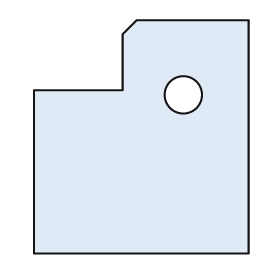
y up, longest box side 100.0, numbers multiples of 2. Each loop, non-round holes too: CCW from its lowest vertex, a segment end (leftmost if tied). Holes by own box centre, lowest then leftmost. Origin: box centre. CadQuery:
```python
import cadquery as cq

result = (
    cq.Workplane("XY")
    .moveTo(-46.0, -50.0)
    .lineTo(46.0, -50.0)
    .lineTo(46.0, 50.0)
    .lineTo(-2.0, 50.0)
    .lineTo(-8.0, 44.0)
    .lineTo(-8.0, 20.0)
    .lineTo(-46.0, 20.0)
    .close()
    .moveTo(18.0, 18.0)
    .circle(8.0)
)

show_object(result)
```